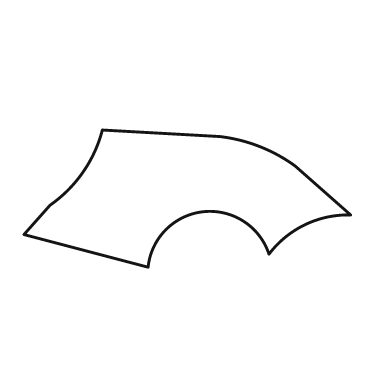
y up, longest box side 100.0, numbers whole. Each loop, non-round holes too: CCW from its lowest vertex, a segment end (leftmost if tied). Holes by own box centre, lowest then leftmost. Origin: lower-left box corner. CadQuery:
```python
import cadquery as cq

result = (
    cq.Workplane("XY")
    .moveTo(38.0, 0.0)
    .threePointArc((55.0, 17.0), (75.0, 4.0))
    .threePointArc((86.0, 13.0), (100.0, 16.0))
    .lineTo(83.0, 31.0)
    .threePointArc((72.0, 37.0), (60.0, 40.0))
    .lineTo(24.0, 42.0)
    .threePointArc((18.0, 29.0), (8.0, 19.0))
    .lineTo(0.0, 10.0)
    .close()
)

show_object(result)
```